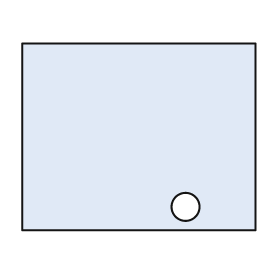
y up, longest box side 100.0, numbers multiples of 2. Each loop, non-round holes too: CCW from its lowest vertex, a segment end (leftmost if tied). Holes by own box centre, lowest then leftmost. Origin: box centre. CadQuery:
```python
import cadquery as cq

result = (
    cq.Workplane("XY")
    .moveTo(-50.0, -40.0)
    .lineTo(50.0, -40.0)
    .lineTo(50.0, 40.0)
    .lineTo(-50.0, 40.0)
    .close()
    .moveTo(20.0, -30.0)
    .circle(6.0)
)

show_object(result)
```